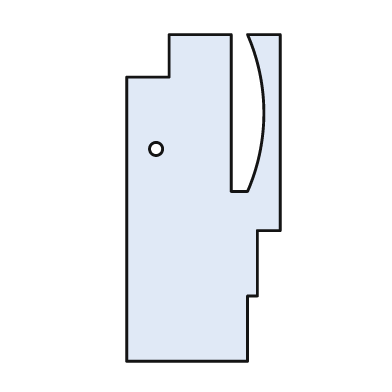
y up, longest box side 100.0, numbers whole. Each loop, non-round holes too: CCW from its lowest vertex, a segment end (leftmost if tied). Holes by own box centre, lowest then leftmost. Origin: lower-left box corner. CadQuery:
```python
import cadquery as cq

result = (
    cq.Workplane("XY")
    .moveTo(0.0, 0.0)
    .lineTo(37.0, 0.0)
    .lineTo(37.0, 20.0)
    .lineTo(40.0, 20.0)
    .lineTo(40.0, 40.0)
    .lineTo(47.0, 40.0)
    .lineTo(47.0, 100.0)
    .lineTo(37.0, 100.0)
    .threePointArc((42.0, 76.0), (37.0, 52.0))
    .lineTo(32.0, 52.0)
    .lineTo(32.0, 100.0)
    .lineTo(13.0, 100.0)
    .lineTo(13.0, 87.0)
    .lineTo(0.0, 87.0)
    .close()
    .moveTo(9.0, 65.0)
    .circle(2.0)
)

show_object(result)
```